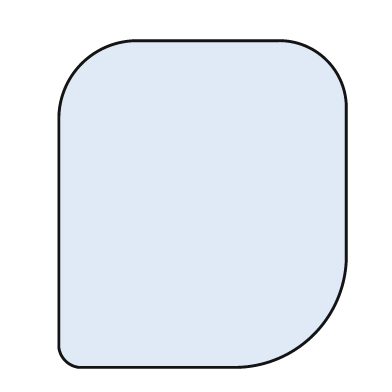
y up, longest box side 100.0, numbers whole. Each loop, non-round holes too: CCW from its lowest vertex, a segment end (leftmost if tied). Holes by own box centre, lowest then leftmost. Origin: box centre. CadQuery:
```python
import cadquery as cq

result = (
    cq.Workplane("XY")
    .moveTo(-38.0, -50.0)
    .lineTo(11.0, -50.0)
    .threePointArc((34.0, -40.0), (44.0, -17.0))
    .lineTo(44.0, 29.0)
    .threePointArc((38.0, 44.0), (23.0, 50.0))
    .lineTo(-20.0, 50.0)
    .threePointArc((-37.0, 43.0), (-44.0, 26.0))
    .lineTo(-44.0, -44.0)
    .threePointArc((-42.0, -48.0), (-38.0, -50.0))
    .close()
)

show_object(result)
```